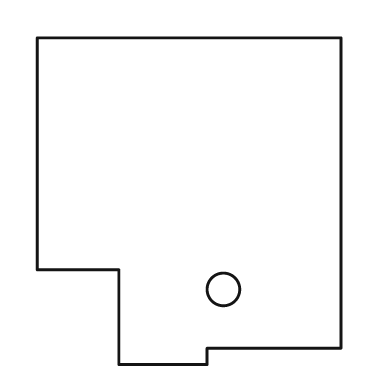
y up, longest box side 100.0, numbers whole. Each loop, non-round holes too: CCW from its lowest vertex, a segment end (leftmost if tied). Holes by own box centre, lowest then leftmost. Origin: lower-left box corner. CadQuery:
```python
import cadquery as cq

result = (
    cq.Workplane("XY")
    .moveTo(25.0, 0.0)
    .lineTo(52.0, 0.0)
    .lineTo(52.0, 5.0)
    .lineTo(93.0, 5.0)
    .lineTo(93.0, 100.0)
    .lineTo(0.0, 100.0)
    .lineTo(0.0, 29.0)
    .lineTo(25.0, 29.0)
    .close()
    .moveTo(57.0, 23.0)
    .circle(5.0)
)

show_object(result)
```